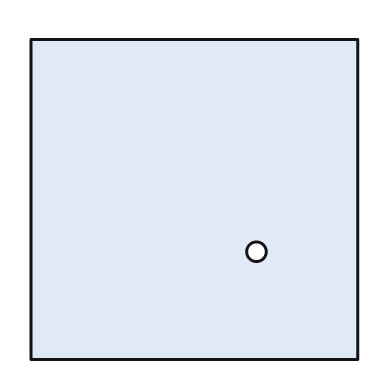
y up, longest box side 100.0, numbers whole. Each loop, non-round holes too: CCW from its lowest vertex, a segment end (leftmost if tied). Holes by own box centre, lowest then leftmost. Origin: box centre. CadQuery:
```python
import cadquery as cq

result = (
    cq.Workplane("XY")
    .moveTo(-50.0, -49.0)
    .lineTo(50.0, -49.0)
    .lineTo(50.0, 49.0)
    .lineTo(-50.0, 49.0)
    .close()
    .moveTo(19.0, -16.0)
    .circle(3.0)
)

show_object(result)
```